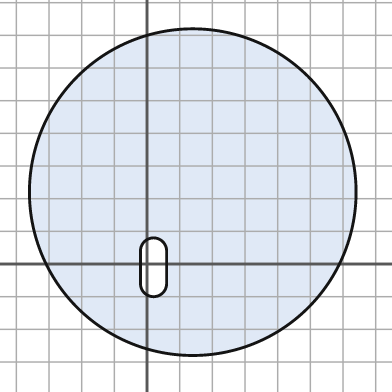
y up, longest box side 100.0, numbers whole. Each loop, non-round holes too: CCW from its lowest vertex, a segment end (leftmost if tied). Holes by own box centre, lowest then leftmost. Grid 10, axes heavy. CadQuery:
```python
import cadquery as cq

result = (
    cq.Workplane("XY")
    .moveTo(14.0, 22.0)
    .circle(50.0)
    .moveTo(-2.0, -6.0)
    .threePointArc((2.0, -10.0), (6.0, -6.0))
    .lineTo(6.0, 4.0)
    .threePointArc((2.0, 8.0), (-2.0, 4.0))
    .close()
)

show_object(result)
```